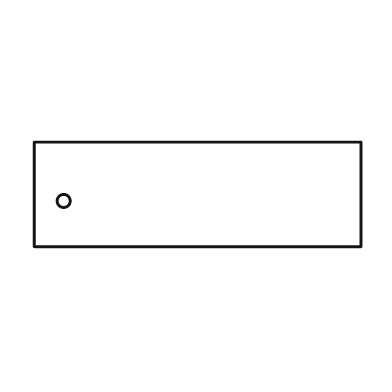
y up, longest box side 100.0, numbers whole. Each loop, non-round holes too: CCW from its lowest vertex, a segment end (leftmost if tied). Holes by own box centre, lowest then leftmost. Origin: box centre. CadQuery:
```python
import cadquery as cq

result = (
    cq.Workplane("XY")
    .moveTo(-50.0, -16.0)
    .lineTo(50.0, -16.0)
    .lineTo(50.0, 16.0)
    .lineTo(-50.0, 16.0)
    .close()
    .moveTo(-41.0, -2.0)
    .circle(2.0)
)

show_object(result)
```